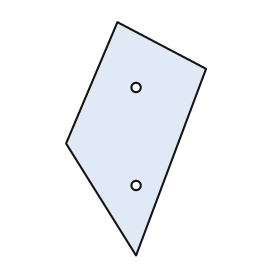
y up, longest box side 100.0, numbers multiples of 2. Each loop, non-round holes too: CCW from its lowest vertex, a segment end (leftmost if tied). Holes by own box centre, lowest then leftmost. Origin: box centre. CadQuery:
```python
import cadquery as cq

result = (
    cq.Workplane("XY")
    .moveTo(0.0, -50.0)
    .lineTo(30.0, 30.0)
    .lineTo(-8.0, 50.0)
    .lineTo(-30.0, -2.0)
    .close()
    .moveTo(0.0, -20.0)
    .circle(2.0)
    .moveTo(0.0, 22.0)
    .circle(2.0)
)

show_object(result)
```